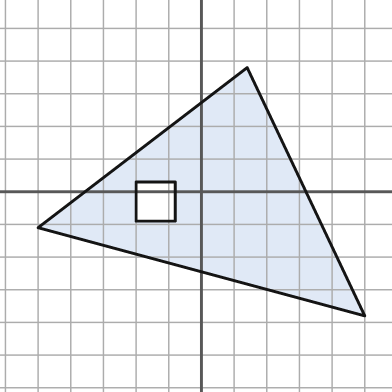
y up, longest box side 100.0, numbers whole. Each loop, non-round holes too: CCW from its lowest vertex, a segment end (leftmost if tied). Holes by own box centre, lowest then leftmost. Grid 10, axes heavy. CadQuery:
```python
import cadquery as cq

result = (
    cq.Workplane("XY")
    .moveTo(50.0, -38.0)
    .lineTo(14.0, 38.0)
    .lineTo(-50.0, -11.0)
    .close()
    .moveTo(-20.0, -9.0)
    .lineTo(-8.0, -9.0)
    .lineTo(-8.0, 3.0)
    .lineTo(-20.0, 3.0)
    .close()
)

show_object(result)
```